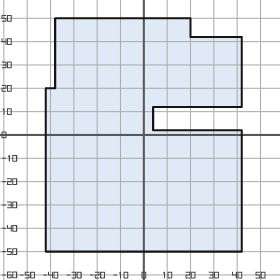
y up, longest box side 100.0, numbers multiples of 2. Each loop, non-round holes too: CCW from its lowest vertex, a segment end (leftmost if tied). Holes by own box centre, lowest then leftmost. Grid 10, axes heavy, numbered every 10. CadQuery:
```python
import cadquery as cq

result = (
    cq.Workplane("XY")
    .moveTo(-42.0, -50.0)
    .lineTo(42.0, -50.0)
    .lineTo(42.0, 2.0)
    .lineTo(4.0, 2.0)
    .lineTo(4.0, 12.0)
    .lineTo(42.0, 12.0)
    .lineTo(42.0, 42.0)
    .lineTo(20.0, 42.0)
    .lineTo(20.0, 50.0)
    .lineTo(-38.0, 50.0)
    .lineTo(-38.0, 20.0)
    .lineTo(-42.0, 20.0)
    .close()
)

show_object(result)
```